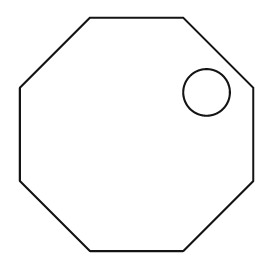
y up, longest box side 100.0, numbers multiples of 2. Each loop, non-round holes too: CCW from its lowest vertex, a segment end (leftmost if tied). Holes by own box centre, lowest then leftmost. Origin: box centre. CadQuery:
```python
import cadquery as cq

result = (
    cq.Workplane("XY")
    .moveTo(-20.0, -50.0)
    .lineTo(20.0, -50.0)
    .lineTo(50.0, -20.0)
    .lineTo(50.0, 20.0)
    .lineTo(20.0, 50.0)
    .lineTo(-20.0, 50.0)
    .lineTo(-50.0, 20.0)
    .lineTo(-50.0, -20.0)
    .close()
    .moveTo(30.0, 18.0)
    .circle(10.0)
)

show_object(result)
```